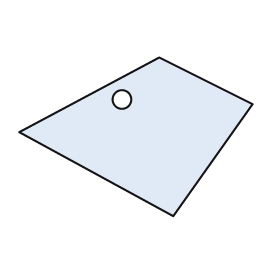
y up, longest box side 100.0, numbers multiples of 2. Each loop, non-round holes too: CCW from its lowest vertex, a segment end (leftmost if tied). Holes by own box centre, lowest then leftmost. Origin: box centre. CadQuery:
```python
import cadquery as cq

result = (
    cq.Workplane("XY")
    .moveTo(16.0, -34.0)
    .lineTo(50.0, 14.0)
    .lineTo(10.0, 34.0)
    .lineTo(-50.0, 2.0)
    .close()
    .moveTo(-6.0, 16.0)
    .circle(4.0)
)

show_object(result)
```